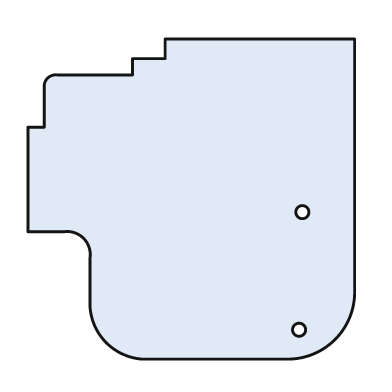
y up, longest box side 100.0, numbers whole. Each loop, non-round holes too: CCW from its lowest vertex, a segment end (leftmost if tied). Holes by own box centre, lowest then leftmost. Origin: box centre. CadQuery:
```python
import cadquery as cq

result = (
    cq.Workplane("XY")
    .moveTo(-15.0, -49.0)
    .lineTo(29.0, -49.0)
    .threePointArc((44.0, -43.0), (50.0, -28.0))
    .lineTo(50.0, 49.0)
    .lineTo(-8.0, 49.0)
    .lineTo(-8.0, 43.0)
    .lineTo(-18.0, 43.0)
    .lineTo(-18.0, 38.0)
    .lineTo(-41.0, 38.0)
    .threePointArc((-44.0, 37.0), (-45.0, 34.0))
    .lineTo(-45.0, 22.0)
    .lineTo(-50.0, 22.0)
    .lineTo(-50.0, -10.0)
    .lineTo(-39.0, -10.0)
    .threePointArc((-33.0, -12.0), (-31.0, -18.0))
    .lineTo(-31.0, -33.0)
    .threePointArc((-26.0, -44.0), (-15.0, -49.0))
    .close()
    .moveTo(33.0, -40.0)
    .circle(2.0)
    .moveTo(34.0, -4.0)
    .circle(2.0)
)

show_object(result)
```